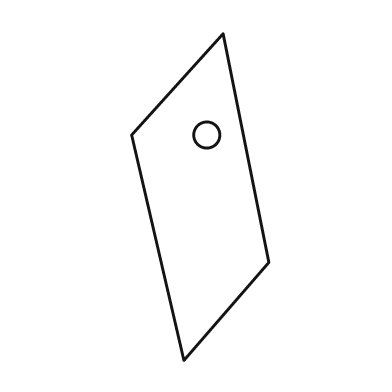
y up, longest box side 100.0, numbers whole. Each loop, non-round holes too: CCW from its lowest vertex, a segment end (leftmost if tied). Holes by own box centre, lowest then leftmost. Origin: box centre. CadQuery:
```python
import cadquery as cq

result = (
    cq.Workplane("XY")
    .moveTo(-5.0, -50.0)
    .lineTo(21.0, -20.0)
    .lineTo(7.0, 50.0)
    .lineTo(-21.0, 19.0)
    .close()
    .moveTo(2.0, 19.0)
    .circle(4.0)
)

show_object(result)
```